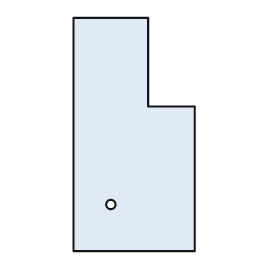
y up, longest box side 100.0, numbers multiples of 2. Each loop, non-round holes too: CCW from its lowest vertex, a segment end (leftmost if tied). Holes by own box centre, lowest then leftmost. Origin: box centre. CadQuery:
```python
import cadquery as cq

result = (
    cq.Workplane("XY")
    .moveTo(-26.0, -50.0)
    .lineTo(26.0, -50.0)
    .lineTo(26.0, 12.0)
    .lineTo(6.0, 12.0)
    .lineTo(6.0, 50.0)
    .lineTo(-26.0, 50.0)
    .close()
    .moveTo(-10.0, -30.0)
    .circle(2.0)
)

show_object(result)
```